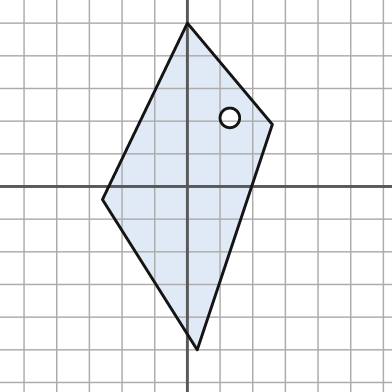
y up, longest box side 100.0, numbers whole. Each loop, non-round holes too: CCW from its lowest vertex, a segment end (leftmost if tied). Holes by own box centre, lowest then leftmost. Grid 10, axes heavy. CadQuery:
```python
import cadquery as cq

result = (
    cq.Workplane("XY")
    .moveTo(3.0, -50.0)
    .lineTo(26.0, 19.0)
    .lineTo(0.0, 50.0)
    .lineTo(-26.0, -4.0)
    .close()
    .moveTo(13.0, 21.0)
    .circle(3.0)
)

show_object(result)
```